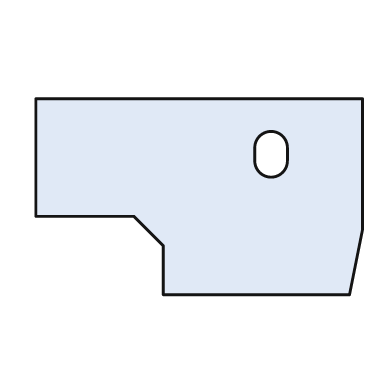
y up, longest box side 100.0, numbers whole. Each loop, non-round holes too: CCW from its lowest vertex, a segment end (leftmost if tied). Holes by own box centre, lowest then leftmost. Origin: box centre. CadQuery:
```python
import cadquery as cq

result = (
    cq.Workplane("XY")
    .moveTo(-11.0, -30.0)
    .lineTo(46.0, -30.0)
    .lineTo(50.0, -10.0)
    .lineTo(50.0, 30.0)
    .lineTo(-50.0, 30.0)
    .lineTo(-50.0, -6.0)
    .lineTo(-20.0, -6.0)
    .lineTo(-11.0, -15.0)
    .close()
    .moveTo(17.0, 11.0)
    .threePointArc((22.0, 6.0), (27.0, 11.0))
    .lineTo(27.0, 15.0)
    .threePointArc((22.0, 20.0), (17.0, 15.0))
    .close()
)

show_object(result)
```